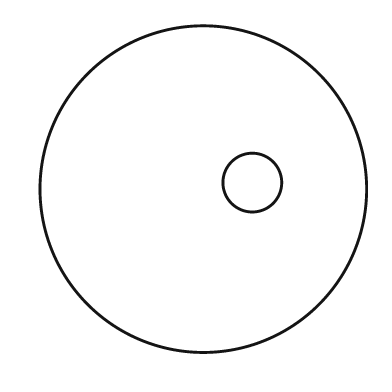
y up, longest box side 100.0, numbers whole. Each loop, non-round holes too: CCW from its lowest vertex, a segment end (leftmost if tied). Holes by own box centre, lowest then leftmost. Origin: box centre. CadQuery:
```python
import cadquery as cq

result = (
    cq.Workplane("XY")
    .moveTo(0.0, 0.0)
    .circle(50.0)
    .moveTo(15.0, 2.0)
    .circle(9.0)
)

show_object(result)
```